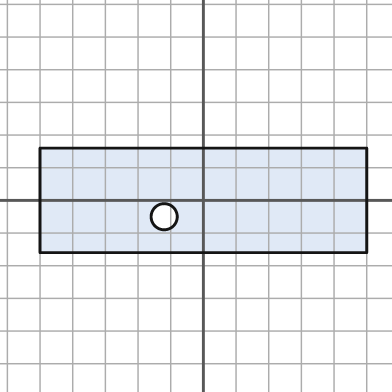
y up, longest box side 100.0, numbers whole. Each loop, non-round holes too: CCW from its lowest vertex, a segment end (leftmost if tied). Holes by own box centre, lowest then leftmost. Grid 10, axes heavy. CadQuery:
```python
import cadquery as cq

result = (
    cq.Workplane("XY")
    .moveTo(-50.0, -16.0)
    .lineTo(50.0, -16.0)
    .lineTo(50.0, 16.0)
    .lineTo(-50.0, 16.0)
    .close()
    .moveTo(-12.0, -5.0)
    .circle(4.0)
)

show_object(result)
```